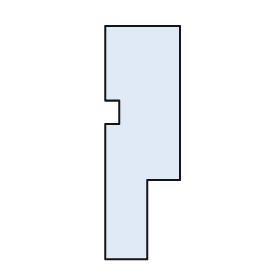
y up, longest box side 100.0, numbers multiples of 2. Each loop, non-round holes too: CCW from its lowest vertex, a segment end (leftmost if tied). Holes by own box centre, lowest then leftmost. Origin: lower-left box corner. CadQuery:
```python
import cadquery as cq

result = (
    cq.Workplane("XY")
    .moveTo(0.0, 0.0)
    .lineTo(18.0, 0.0)
    .lineTo(18.0, 34.0)
    .lineTo(32.0, 34.0)
    .lineTo(32.0, 100.0)
    .lineTo(0.0, 100.0)
    .lineTo(0.0, 68.0)
    .lineTo(6.0, 68.0)
    .lineTo(6.0, 58.0)
    .lineTo(0.0, 58.0)
    .close()
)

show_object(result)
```